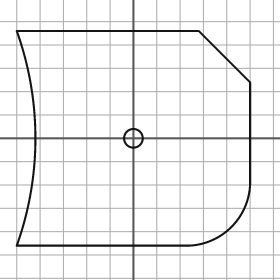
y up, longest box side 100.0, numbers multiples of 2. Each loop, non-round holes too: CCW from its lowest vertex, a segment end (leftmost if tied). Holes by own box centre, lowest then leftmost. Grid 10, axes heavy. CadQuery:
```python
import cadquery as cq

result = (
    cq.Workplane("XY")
    .moveTo(-50.0, -46.0)
    .lineTo(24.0, -46.0)
    .threePointArc((42.0, -38.0), (50.0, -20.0))
    .lineTo(50.0, 24.0)
    .lineTo(28.0, 46.0)
    .lineTo(-50.0, 46.0)
    .threePointArc((-42.0, 0.0), (-50.0, -46.0))
    .close()
    .moveTo(0.0, 0.0)
    .circle(4.0)
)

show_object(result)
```